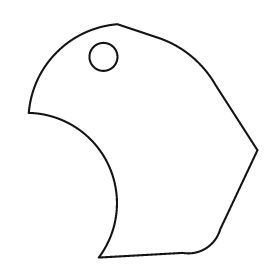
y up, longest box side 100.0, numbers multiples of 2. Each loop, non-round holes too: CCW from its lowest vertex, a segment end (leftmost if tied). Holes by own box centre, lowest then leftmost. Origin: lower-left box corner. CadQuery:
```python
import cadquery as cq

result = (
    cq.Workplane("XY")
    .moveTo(30.0, 0.0)
    .lineTo(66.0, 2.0)
    .threePointArc((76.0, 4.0), (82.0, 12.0))
    .lineTo(98.0, 46.0)
    .lineTo(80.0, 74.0)
    .threePointArc((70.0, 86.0), (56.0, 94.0))
    .lineTo(38.0, 100.0)
    .threePointArc((12.0, 88.0), (0.0, 62.0))
    .threePointArc((34.0, 40.0), (30.0, 0.0))
    .close()
    .moveTo(32.0, 86.0)
    .circle(6.0)
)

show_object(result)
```